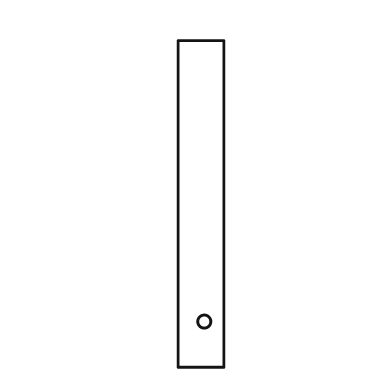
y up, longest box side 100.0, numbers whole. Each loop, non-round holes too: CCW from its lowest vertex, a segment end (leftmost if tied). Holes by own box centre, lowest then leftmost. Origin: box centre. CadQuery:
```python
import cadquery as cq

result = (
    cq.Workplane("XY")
    .moveTo(-7.0, -50.0)
    .lineTo(7.0, -50.0)
    .lineTo(7.0, 50.0)
    .lineTo(-7.0, 50.0)
    .close()
    .moveTo(1.0, -36.0)
    .circle(2.0)
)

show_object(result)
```